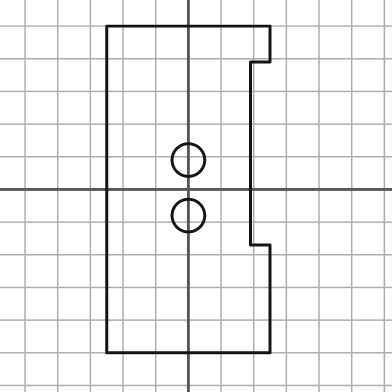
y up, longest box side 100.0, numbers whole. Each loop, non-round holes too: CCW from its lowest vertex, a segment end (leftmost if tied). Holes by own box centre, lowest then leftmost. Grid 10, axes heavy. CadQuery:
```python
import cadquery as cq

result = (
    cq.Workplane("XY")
    .moveTo(-25.0, -50.0)
    .lineTo(25.0, -50.0)
    .lineTo(25.0, -17.0)
    .lineTo(19.0, -17.0)
    .lineTo(19.0, 39.0)
    .lineTo(25.0, 39.0)
    .lineTo(25.0, 50.0)
    .lineTo(-25.0, 50.0)
    .close()
    .moveTo(0.0, -8.0)
    .circle(5.0)
    .moveTo(0.0, 9.0)
    .circle(5.0)
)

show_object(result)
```